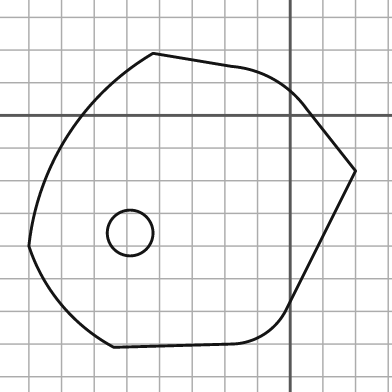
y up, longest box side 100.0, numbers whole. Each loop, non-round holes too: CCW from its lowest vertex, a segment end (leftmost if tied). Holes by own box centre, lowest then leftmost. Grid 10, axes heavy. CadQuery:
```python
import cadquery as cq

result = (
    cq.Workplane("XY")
    .moveTo(-54.0, -71.0)
    .lineTo(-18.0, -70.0)
    .threePointArc((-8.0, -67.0), (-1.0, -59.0))
    .lineTo(20.0, -17.0)
    .lineTo(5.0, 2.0)
    .threePointArc((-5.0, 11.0), (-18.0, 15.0))
    .lineTo(-42.0, 19.0)
    .threePointArc((-68.0, -6.0), (-80.0, -40.0))
    .threePointArc((-70.0, -58.0), (-54.0, -71.0))
    .close()
    .moveTo(-49.0, -36.0)
    .circle(7.0)
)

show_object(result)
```